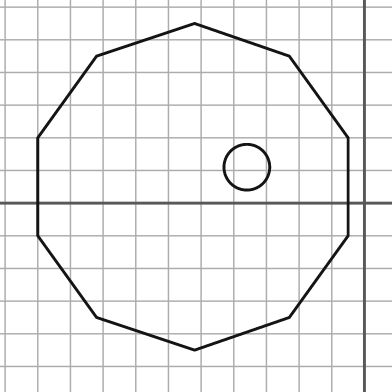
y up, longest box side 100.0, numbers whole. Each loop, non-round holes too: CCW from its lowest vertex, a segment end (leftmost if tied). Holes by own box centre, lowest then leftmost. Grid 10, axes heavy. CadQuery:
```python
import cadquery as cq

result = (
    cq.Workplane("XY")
    .moveTo(-52.0, -45.0)
    .lineTo(-23.0, -35.0)
    .lineTo(-5.0, -10.0)
    .lineTo(-5.0, 20.0)
    .lineTo(-23.0, 45.0)
    .lineTo(-52.0, 55.0)
    .lineTo(-82.0, 45.0)
    .lineTo(-100.0, 20.0)
    .lineTo(-100.0, -10.0)
    .lineTo(-82.0, -35.0)
    .close()
    .moveTo(-36.0, 11.0)
    .circle(7.0)
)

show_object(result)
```